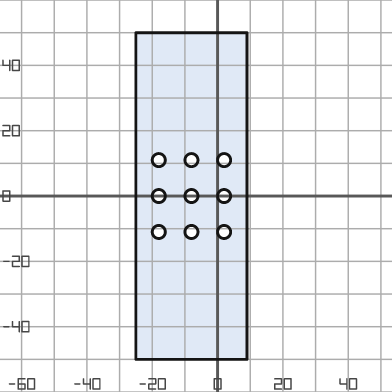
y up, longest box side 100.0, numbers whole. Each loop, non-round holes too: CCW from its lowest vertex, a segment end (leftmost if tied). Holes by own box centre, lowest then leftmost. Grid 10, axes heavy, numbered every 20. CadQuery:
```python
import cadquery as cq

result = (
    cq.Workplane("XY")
    .moveTo(-25.0, -50.0)
    .lineTo(9.0, -50.0)
    .lineTo(9.0, 50.0)
    .lineTo(-25.0, 50.0)
    .close()
    .moveTo(-18.0, -11.0)
    .circle(2.0)
    .moveTo(-8.0, -11.0)
    .circle(2.0)
    .moveTo(2.0, -11.0)
    .circle(2.0)
    .moveTo(-18.0, 0.0)
    .circle(2.0)
    .moveTo(-8.0, 0.0)
    .circle(2.0)
    .moveTo(2.0, 0.0)
    .circle(2.0)
    .moveTo(-18.0, 11.0)
    .circle(2.0)
    .moveTo(-8.0, 11.0)
    .circle(2.0)
    .moveTo(2.0, 11.0)
    .circle(2.0)
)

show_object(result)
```